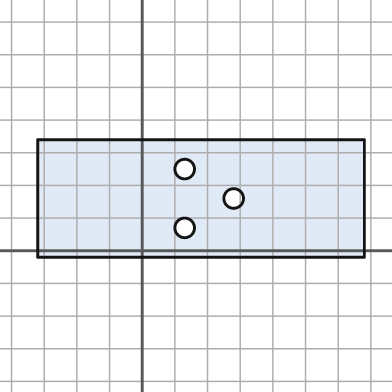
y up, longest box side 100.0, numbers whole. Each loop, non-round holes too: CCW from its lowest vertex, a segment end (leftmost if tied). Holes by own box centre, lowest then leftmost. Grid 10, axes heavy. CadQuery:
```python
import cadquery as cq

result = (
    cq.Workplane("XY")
    .moveTo(-32.0, -2.0)
    .lineTo(68.0, -2.0)
    .lineTo(68.0, 34.0)
    .lineTo(-32.0, 34.0)
    .close()
    .moveTo(13.0, 7.0)
    .circle(3.0)
    .moveTo(28.0, 16.0)
    .circle(3.0)
    .moveTo(13.0, 25.0)
    .circle(3.0)
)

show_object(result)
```